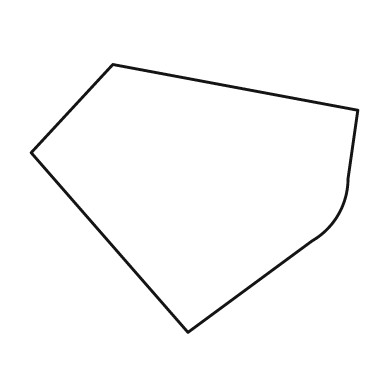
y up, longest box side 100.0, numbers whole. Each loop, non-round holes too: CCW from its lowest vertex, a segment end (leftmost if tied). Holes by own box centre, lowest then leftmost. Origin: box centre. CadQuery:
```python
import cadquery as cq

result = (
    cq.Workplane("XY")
    .moveTo(-2.0, -41.0)
    .lineTo(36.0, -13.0)
    .threePointArc((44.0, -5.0), (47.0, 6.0))
    .lineTo(50.0, 27.0)
    .lineTo(-25.0, 41.0)
    .lineTo(-50.0, 14.0)
    .close()
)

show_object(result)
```